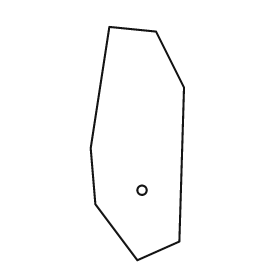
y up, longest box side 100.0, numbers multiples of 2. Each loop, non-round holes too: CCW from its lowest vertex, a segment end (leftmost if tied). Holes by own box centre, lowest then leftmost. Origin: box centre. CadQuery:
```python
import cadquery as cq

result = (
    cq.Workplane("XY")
    .moveTo(0.0, -50.0)
    .lineTo(18.0, -42.0)
    .lineTo(20.0, 24.0)
    .lineTo(8.0, 48.0)
    .lineTo(-12.0, 50.0)
    .lineTo(-20.0, -2.0)
    .lineTo(-18.0, -26.0)
    .close()
    .moveTo(2.0, -20.0)
    .circle(2.0)
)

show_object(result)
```